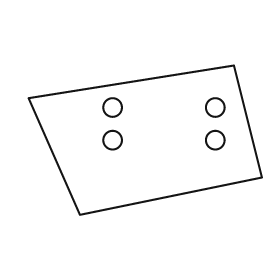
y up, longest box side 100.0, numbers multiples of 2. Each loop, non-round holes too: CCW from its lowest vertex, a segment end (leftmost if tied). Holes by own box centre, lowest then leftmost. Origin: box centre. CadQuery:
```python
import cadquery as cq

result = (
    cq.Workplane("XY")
    .moveTo(-28.0, -32.0)
    .lineTo(50.0, -16.0)
    .lineTo(38.0, 32.0)
    .lineTo(-50.0, 18.0)
    .close()
    .moveTo(-14.0, 0.0)
    .circle(4.0)
    .moveTo(30.0, 0.0)
    .circle(4.0)
    .moveTo(-14.0, 14.0)
    .circle(4.0)
    .moveTo(30.0, 14.0)
    .circle(4.0)
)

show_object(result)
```